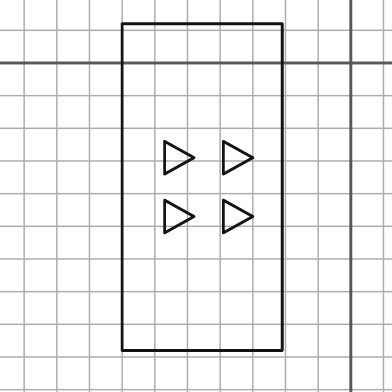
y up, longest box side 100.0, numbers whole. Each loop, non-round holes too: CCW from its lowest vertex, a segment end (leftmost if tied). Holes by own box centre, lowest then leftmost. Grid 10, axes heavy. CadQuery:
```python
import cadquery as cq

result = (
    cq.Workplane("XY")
    .moveTo(-70.0, -88.0)
    .lineTo(-21.0, -88.0)
    .lineTo(-21.0, 12.0)
    .lineTo(-70.0, 12.0)
    .close()
    .moveTo(-57.0, -52.0)
    .lineTo(-48.0, -47.0)
    .lineTo(-57.0, -42.0)
    .close()
    .moveTo(-39.0, -52.0)
    .lineTo(-30.0, -47.0)
    .lineTo(-39.0, -42.0)
    .close()
    .moveTo(-57.0, -34.0)
    .lineTo(-48.0, -29.0)
    .lineTo(-57.0, -24.0)
    .close()
    .moveTo(-39.0, -34.0)
    .lineTo(-30.0, -29.0)
    .lineTo(-39.0, -24.0)
    .close()
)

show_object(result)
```